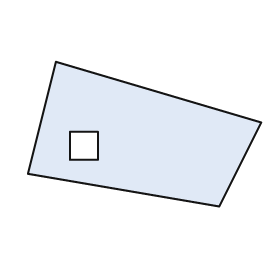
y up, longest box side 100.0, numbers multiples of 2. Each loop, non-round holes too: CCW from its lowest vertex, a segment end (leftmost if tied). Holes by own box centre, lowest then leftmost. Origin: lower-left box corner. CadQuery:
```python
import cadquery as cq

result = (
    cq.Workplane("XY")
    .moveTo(82.0, 0.0)
    .lineTo(100.0, 36.0)
    .lineTo(12.0, 62.0)
    .lineTo(0.0, 14.0)
    .close()
    .moveTo(18.0, 20.0)
    .lineTo(30.0, 20.0)
    .lineTo(30.0, 32.0)
    .lineTo(18.0, 32.0)
    .close()
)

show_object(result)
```